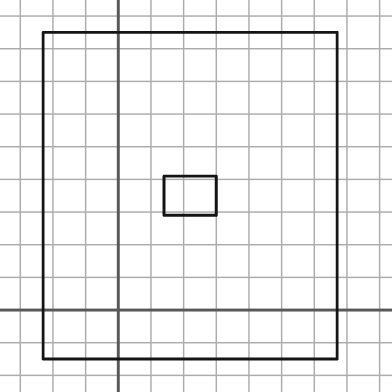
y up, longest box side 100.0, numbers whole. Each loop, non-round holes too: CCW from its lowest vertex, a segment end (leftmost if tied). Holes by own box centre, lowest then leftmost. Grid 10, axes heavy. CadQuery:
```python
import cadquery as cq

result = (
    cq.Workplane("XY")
    .moveTo(-23.0, -15.0)
    .lineTo(67.0, -15.0)
    .lineTo(67.0, 85.0)
    .lineTo(-23.0, 85.0)
    .close()
    .moveTo(14.0, 29.0)
    .lineTo(30.0, 29.0)
    .lineTo(30.0, 41.0)
    .lineTo(14.0, 41.0)
    .close()
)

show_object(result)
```